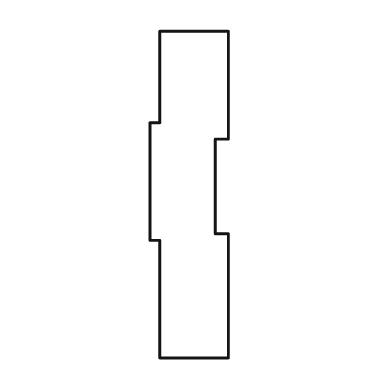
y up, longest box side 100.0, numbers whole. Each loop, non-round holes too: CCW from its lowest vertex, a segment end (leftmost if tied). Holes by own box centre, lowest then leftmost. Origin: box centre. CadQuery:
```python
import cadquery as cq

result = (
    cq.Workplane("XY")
    .moveTo(-9.0, -50.0)
    .lineTo(12.0, -50.0)
    .lineTo(12.0, -12.0)
    .lineTo(8.0, -12.0)
    .lineTo(8.0, 17.0)
    .lineTo(12.0, 17.0)
    .lineTo(12.0, 50.0)
    .lineTo(-9.0, 50.0)
    .lineTo(-9.0, 22.0)
    .lineTo(-12.0, 22.0)
    .lineTo(-12.0, -14.0)
    .lineTo(-9.0, -14.0)
    .close()
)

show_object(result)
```